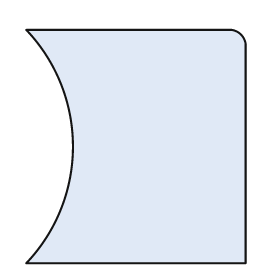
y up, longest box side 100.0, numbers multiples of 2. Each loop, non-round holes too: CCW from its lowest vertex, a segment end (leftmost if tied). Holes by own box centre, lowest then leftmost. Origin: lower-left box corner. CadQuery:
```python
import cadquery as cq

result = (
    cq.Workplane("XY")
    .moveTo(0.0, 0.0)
    .lineTo(94.0, 0.0)
    .lineTo(94.0, 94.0)
    .threePointArc((92.0, 98.0), (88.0, 100.0))
    .lineTo(0.0, 100.0)
    .threePointArc((20.0, 50.0), (0.0, 0.0))
    .close()
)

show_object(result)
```